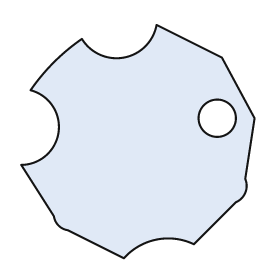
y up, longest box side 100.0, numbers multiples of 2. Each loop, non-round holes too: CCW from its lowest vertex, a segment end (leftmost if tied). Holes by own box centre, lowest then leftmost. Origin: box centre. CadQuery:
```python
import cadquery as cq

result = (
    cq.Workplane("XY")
    .moveTo(-6.0, -50.0)
    .threePointArc((8.0, -42.0), (24.0, -44.0))
    .lineTo(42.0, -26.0)
    .threePointArc((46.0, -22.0), (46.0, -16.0))
    .lineTo(50.0, 10.0)
    .lineTo(36.0, 36.0)
    .lineTo(8.0, 50.0)
    .threePointArc((-6.0, 36.0), (-24.0, 44.0))
    .threePointArc((-36.0, 34.0), (-46.0, 22.0))
    .threePointArc((-34.0, 4.0), (-50.0, -10.0))
    .lineTo(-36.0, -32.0)
    .threePointArc((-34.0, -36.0), (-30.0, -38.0))
    .close()
    .moveTo(34.0, 10.0)
    .circle(8.0)
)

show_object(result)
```